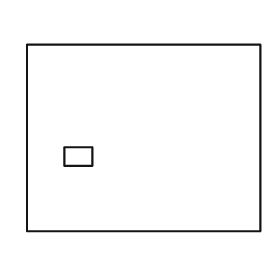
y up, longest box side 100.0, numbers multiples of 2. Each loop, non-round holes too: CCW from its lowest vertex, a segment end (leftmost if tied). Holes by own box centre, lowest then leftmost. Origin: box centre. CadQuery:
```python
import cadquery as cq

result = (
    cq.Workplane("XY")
    .moveTo(-50.0, -40.0)
    .lineTo(50.0, -40.0)
    .lineTo(50.0, 40.0)
    .lineTo(-50.0, 40.0)
    .close()
    .moveTo(-34.0, -12.0)
    .lineTo(-22.0, -12.0)
    .lineTo(-22.0, -4.0)
    .lineTo(-34.0, -4.0)
    .close()
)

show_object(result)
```